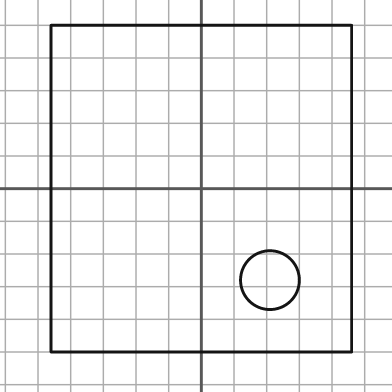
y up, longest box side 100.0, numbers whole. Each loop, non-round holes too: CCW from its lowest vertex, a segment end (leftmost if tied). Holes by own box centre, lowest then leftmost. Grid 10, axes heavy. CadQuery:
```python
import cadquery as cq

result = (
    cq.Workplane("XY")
    .moveTo(-46.0, -50.0)
    .lineTo(46.0, -50.0)
    .lineTo(46.0, 50.0)
    .lineTo(-46.0, 50.0)
    .close()
    .moveTo(21.0, -28.0)
    .circle(9.0)
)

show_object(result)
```